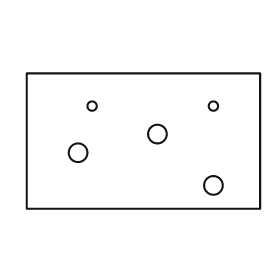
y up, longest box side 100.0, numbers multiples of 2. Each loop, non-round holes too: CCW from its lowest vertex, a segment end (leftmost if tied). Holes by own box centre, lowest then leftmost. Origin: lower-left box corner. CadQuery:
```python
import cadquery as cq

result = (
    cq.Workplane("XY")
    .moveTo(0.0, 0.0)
    .lineTo(100.0, 0.0)
    .lineTo(100.0, 58.0)
    .lineTo(0.0, 58.0)
    .close()
    .moveTo(80.0, 10.0)
    .circle(4.0)
    .moveTo(22.0, 24.0)
    .circle(4.0)
    .moveTo(56.0, 32.0)
    .circle(4.0)
    .moveTo(28.0, 44.0)
    .circle(2.0)
    .moveTo(80.0, 44.0)
    .circle(2.0)
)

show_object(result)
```